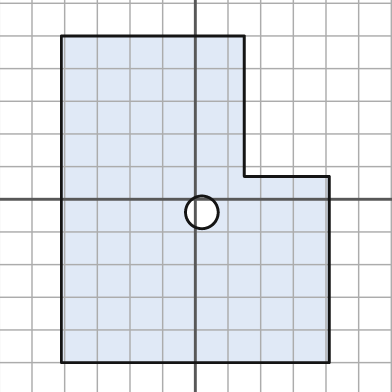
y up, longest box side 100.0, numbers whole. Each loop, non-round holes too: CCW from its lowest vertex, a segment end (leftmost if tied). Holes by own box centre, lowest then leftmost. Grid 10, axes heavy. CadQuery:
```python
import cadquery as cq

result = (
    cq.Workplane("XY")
    .moveTo(-41.0, -50.0)
    .lineTo(41.0, -50.0)
    .lineTo(41.0, 7.0)
    .lineTo(15.0, 7.0)
    .lineTo(15.0, 50.0)
    .lineTo(-41.0, 50.0)
    .close()
    .moveTo(2.0, -4.0)
    .circle(5.0)
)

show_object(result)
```